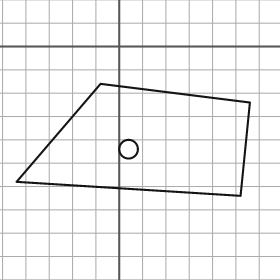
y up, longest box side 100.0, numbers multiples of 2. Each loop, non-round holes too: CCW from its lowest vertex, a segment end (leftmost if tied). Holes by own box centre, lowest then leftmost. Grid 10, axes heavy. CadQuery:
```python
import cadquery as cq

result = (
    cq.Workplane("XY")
    .moveTo(52.0, -64.0)
    .lineTo(56.0, -24.0)
    .lineTo(-8.0, -16.0)
    .lineTo(-44.0, -58.0)
    .close()
    .moveTo(4.0, -44.0)
    .circle(4.0)
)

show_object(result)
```